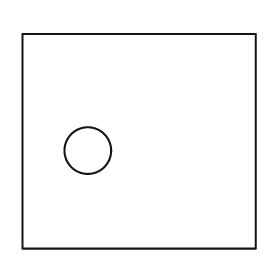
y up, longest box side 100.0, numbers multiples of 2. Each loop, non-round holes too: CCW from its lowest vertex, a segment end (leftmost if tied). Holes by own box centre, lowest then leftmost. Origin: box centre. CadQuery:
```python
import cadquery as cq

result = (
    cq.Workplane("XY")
    .moveTo(-50.0, -46.0)
    .lineTo(50.0, -46.0)
    .lineTo(50.0, 46.0)
    .lineTo(-50.0, 46.0)
    .close()
    .moveTo(-22.0, -4.0)
    .circle(10.0)
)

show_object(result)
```